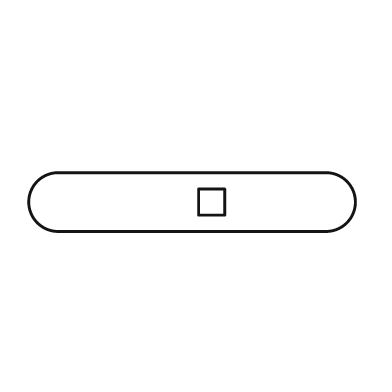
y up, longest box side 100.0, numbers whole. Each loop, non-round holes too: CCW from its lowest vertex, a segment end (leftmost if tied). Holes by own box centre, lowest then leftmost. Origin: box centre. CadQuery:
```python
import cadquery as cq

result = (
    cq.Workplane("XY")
    .moveTo(-41.0, -9.0)
    .lineTo(41.0, -9.0)
    .threePointArc((50.0, 0.0), (41.0, 9.0))
    .lineTo(-41.0, 9.0)
    .threePointArc((-50.0, 0.0), (-41.0, -9.0))
    .close()
    .moveTo(2.0, -4.0)
    .lineTo(10.0, -4.0)
    .lineTo(10.0, 4.0)
    .lineTo(2.0, 4.0)
    .close()
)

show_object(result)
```